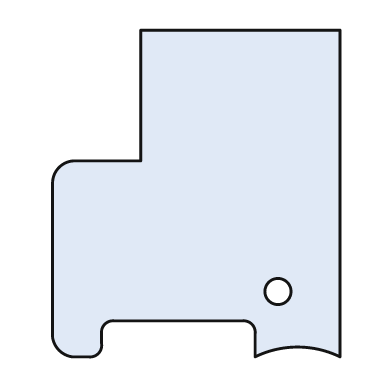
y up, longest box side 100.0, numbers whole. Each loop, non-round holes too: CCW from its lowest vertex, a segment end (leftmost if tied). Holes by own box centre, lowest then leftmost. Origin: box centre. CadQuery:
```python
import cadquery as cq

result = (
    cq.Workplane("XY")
    .moveTo(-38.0, -50.0)
    .lineTo(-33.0, -50.0)
    .threePointArc((-30.0, -49.0), (-29.0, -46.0))
    .lineTo(-29.0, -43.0)
    .threePointArc((-28.0, -40.0), (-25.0, -39.0))
    .lineTo(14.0, -39.0)
    .threePointArc((17.0, -40.0), (18.0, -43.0))
    .lineTo(18.0, -50.0)
    .threePointArc((31.0, -47.0), (44.0, -50.0))
    .lineTo(44.0, 50.0)
    .lineTo(-17.0, 50.0)
    .lineTo(-17.0, 10.0)
    .lineTo(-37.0, 10.0)
    .threePointArc((-42.0, 8.0), (-44.0, 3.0))
    .lineTo(-44.0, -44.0)
    .threePointArc((-42.0, -48.0), (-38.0, -50.0))
    .close()
    .moveTo(25.0, -30.0)
    .circle(4.0)
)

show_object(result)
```